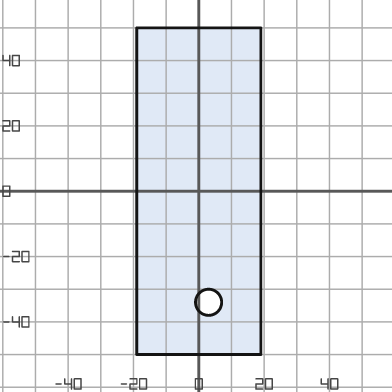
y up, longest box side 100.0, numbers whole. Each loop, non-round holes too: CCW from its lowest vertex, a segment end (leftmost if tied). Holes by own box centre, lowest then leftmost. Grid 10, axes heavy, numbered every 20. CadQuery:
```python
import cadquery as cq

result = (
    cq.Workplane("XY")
    .moveTo(-19.0, -50.0)
    .lineTo(19.0, -50.0)
    .lineTo(19.0, 50.0)
    .lineTo(-19.0, 50.0)
    .close()
    .moveTo(3.0, -34.0)
    .circle(4.0)
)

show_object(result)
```